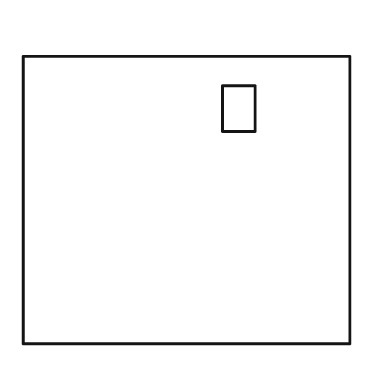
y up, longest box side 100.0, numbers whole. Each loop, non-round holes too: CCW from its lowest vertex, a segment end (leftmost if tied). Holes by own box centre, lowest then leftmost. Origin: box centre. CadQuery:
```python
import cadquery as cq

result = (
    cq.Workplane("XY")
    .moveTo(-50.0, -44.0)
    .lineTo(50.0, -44.0)
    .lineTo(50.0, 44.0)
    .lineTo(-50.0, 44.0)
    .close()
    .moveTo(11.0, 21.0)
    .lineTo(21.0, 21.0)
    .lineTo(21.0, 35.0)
    .lineTo(11.0, 35.0)
    .close()
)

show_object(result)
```